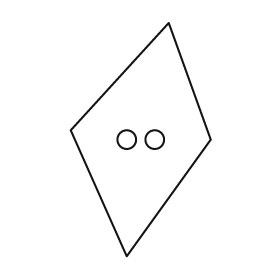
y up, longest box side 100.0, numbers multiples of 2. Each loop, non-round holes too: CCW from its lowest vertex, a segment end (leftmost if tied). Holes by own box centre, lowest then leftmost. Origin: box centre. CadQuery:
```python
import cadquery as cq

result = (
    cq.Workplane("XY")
    .moveTo(-6.0, -50.0)
    .lineTo(30.0, 0.0)
    .lineTo(12.0, 50.0)
    .lineTo(-30.0, 4.0)
    .close()
    .moveTo(-6.0, 0.0)
    .circle(4.0)
    .moveTo(6.0, 0.0)
    .circle(4.0)
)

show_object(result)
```